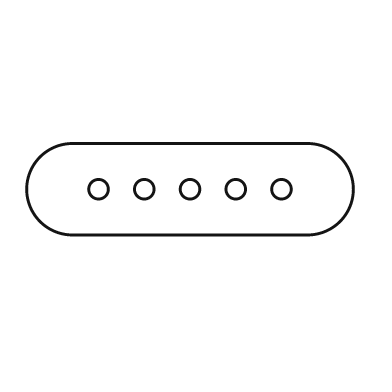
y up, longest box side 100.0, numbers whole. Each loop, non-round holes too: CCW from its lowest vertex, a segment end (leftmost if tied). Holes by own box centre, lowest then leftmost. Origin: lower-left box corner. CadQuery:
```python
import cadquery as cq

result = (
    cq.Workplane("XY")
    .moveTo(14.0, 0.0)
    .lineTo(86.0, 0.0)
    .threePointArc((100.0, 14.0), (86.0, 28.0))
    .lineTo(14.0, 28.0)
    .threePointArc((0.0, 14.0), (14.0, 0.0))
    .close()
    .moveTo(22.0, 14.0)
    .circle(3.0)
    .moveTo(36.0, 14.0)
    .circle(3.0)
    .moveTo(50.0, 14.0)
    .circle(3.0)
    .moveTo(64.0, 14.0)
    .circle(3.0)
    .moveTo(78.0, 14.0)
    .circle(3.0)
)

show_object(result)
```